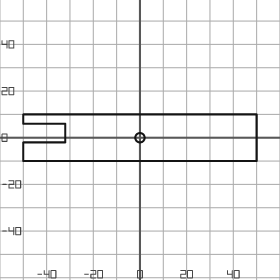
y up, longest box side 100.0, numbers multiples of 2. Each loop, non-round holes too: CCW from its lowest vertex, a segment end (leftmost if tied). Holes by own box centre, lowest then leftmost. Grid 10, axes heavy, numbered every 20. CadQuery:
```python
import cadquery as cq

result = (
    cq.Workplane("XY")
    .moveTo(-50.0, -10.0)
    .lineTo(50.0, -10.0)
    .lineTo(50.0, 10.0)
    .lineTo(-50.0, 10.0)
    .lineTo(-50.0, 6.0)
    .lineTo(-32.0, 6.0)
    .lineTo(-32.0, -2.0)
    .lineTo(-50.0, -2.0)
    .close()
    .moveTo(0.0, 0.0)
    .circle(2.0)
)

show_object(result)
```